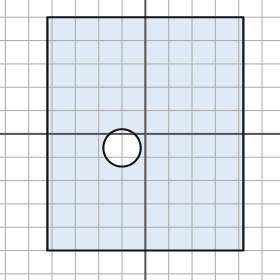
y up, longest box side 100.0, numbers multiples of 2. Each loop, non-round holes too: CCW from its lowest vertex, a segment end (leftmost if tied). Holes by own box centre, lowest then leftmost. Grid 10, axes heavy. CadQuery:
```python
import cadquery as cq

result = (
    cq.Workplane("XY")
    .moveTo(-42.0, -50.0)
    .lineTo(42.0, -50.0)
    .lineTo(42.0, 50.0)
    .lineTo(-42.0, 50.0)
    .close()
    .moveTo(-10.0, -6.0)
    .circle(8.0)
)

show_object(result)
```